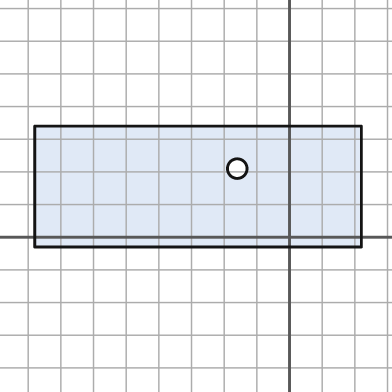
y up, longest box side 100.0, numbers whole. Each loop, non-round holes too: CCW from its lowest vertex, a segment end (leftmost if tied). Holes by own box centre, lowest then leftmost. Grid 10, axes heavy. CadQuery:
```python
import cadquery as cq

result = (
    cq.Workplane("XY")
    .moveTo(-78.0, -3.0)
    .lineTo(22.0, -3.0)
    .lineTo(22.0, 34.0)
    .lineTo(-78.0, 34.0)
    .close()
    .moveTo(-16.0, 21.0)
    .circle(3.0)
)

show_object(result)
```